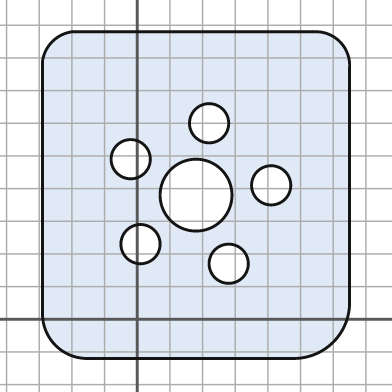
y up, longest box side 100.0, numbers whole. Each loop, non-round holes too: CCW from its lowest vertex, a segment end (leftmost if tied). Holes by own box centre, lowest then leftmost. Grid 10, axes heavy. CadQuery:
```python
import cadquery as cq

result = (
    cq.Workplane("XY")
    .moveTo(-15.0, -12.0)
    .lineTo(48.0, -12.0)
    .threePointArc((60.0, -7.0), (65.0, 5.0))
    .lineTo(65.0, 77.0)
    .threePointArc((62.0, 85.0), (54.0, 88.0))
    .lineTo(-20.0, 88.0)
    .threePointArc((-26.0, 85.0), (-29.0, 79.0))
    .lineTo(-29.0, 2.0)
    .threePointArc((-25.0, -8.0), (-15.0, -12.0))
    .close()
    .moveTo(28.0, 17.0)
    .circle(6.0)
    .moveTo(1.0, 23.0)
    .circle(6.0)
    .moveTo(18.0, 38.0)
    .circle(11.0)
    .moveTo(41.0, 41.0)
    .circle(6.0)
    .moveTo(-2.0, 49.0)
    .circle(6.0)
    .moveTo(22.0, 60.0)
    .circle(6.0)
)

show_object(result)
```